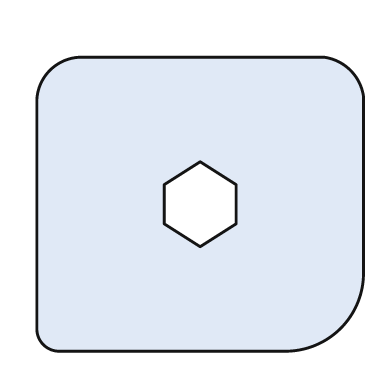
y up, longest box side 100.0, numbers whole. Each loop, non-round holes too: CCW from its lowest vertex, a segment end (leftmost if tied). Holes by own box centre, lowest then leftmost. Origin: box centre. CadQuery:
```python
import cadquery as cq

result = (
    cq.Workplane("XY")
    .moveTo(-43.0, -45.0)
    .lineTo(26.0, -45.0)
    .threePointArc((43.0, -38.0), (50.0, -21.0))
    .lineTo(50.0, 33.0)
    .threePointArc((46.0, 41.0), (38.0, 45.0))
    .lineTo(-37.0, 45.0)
    .threePointArc((-46.0, 41.0), (-50.0, 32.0))
    .lineTo(-50.0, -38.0)
    .threePointArc((-48.0, -43.0), (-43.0, -45.0))
    .close()
    .moveTo(0.0, -13.0)
    .lineTo(11.0, -6.0)
    .lineTo(11.0, 6.0)
    .lineTo(0.0, 13.0)
    .lineTo(-11.0, 6.0)
    .lineTo(-11.0, -6.0)
    .close()
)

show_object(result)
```